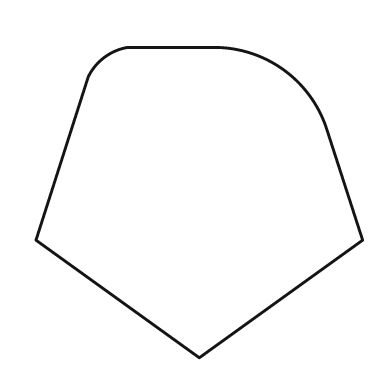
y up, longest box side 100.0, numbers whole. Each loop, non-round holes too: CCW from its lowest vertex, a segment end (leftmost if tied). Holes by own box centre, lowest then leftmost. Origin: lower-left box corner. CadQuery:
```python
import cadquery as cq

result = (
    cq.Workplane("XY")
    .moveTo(50.0, 0.0)
    .lineTo(100.0, 36.0)
    .lineTo(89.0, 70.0)
    .threePointArc((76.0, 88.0), (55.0, 95.0))
    .lineTo(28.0, 95.0)
    .threePointArc((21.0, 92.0), (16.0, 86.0))
    .lineTo(0.0, 36.0)
    .close()
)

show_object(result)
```